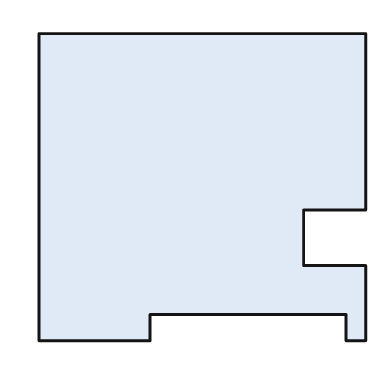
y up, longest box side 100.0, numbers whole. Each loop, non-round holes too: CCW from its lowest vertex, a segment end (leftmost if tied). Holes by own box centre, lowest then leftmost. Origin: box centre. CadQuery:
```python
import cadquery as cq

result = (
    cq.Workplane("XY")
    .moveTo(-50.0, -47.0)
    .lineTo(-16.0, -47.0)
    .lineTo(-16.0, -39.0)
    .lineTo(44.0, -39.0)
    .lineTo(44.0, -47.0)
    .lineTo(50.0, -47.0)
    .lineTo(50.0, -24.0)
    .lineTo(31.0, -24.0)
    .lineTo(31.0, -7.0)
    .lineTo(50.0, -7.0)
    .lineTo(50.0, 47.0)
    .lineTo(-50.0, 47.0)
    .close()
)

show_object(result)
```